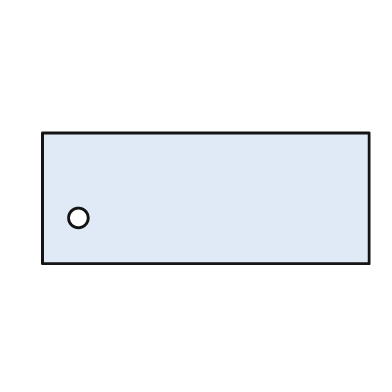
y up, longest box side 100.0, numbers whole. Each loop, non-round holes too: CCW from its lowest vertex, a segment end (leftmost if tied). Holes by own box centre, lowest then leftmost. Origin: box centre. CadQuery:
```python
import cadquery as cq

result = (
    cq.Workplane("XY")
    .moveTo(-50.0, -20.0)
    .lineTo(50.0, -20.0)
    .lineTo(50.0, 20.0)
    .lineTo(-50.0, 20.0)
    .close()
    .moveTo(-39.0, -6.0)
    .circle(3.0)
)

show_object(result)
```